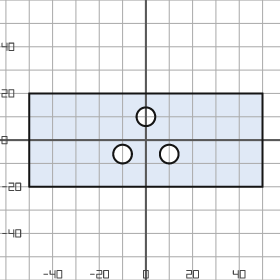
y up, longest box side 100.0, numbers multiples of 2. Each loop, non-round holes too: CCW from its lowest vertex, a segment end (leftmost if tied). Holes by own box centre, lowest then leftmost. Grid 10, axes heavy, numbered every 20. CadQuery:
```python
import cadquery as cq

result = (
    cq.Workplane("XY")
    .moveTo(-50.0, -20.0)
    .lineTo(50.0, -20.0)
    .lineTo(50.0, 20.0)
    .lineTo(-50.0, 20.0)
    .close()
    .moveTo(-10.0, -6.0)
    .circle(4.0)
    .moveTo(10.0, -6.0)
    .circle(4.0)
    .moveTo(0.0, 10.0)
    .circle(4.0)
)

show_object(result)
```